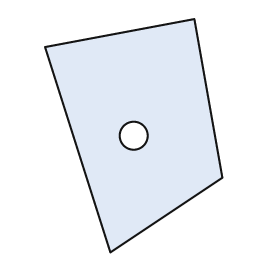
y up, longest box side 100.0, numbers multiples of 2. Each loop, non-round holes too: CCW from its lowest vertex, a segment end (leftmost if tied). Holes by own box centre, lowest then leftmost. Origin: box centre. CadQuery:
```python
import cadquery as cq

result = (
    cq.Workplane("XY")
    .moveTo(-10.0, -50.0)
    .lineTo(38.0, -18.0)
    .lineTo(26.0, 50.0)
    .lineTo(-38.0, 38.0)
    .close()
    .moveTo(0.0, 0.0)
    .circle(6.0)
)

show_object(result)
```